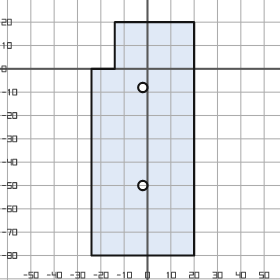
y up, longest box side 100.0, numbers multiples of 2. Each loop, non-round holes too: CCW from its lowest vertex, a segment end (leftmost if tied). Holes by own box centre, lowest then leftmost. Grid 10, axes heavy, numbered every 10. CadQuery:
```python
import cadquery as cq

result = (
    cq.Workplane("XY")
    .moveTo(-24.0, -80.0)
    .lineTo(20.0, -80.0)
    .lineTo(20.0, 20.0)
    .lineTo(-14.0, 20.0)
    .lineTo(-14.0, 0.0)
    .lineTo(-24.0, 0.0)
    .close()
    .moveTo(-2.0, -50.0)
    .circle(2.0)
    .moveTo(-2.0, -8.0)
    .circle(2.0)
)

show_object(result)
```